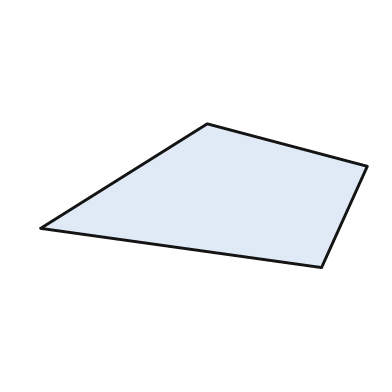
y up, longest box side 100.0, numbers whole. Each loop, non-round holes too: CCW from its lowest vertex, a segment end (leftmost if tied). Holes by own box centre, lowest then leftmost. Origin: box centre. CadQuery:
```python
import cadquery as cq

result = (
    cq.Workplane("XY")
    .moveTo(36.0, -22.0)
    .lineTo(50.0, 9.0)
    .lineTo(1.0, 22.0)
    .lineTo(-50.0, -10.0)
    .close()
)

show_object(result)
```